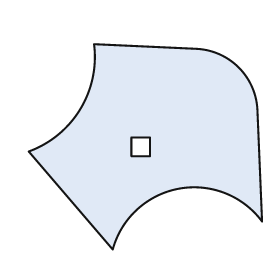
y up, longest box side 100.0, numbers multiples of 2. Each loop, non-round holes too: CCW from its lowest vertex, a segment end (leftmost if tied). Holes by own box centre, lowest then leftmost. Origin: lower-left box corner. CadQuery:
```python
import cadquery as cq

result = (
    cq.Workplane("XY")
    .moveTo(36.0, 0.0)
    .threePointArc((64.0, 26.0), (100.0, 12.0))
    .lineTo(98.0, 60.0)
    .threePointArc((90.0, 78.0), (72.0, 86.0))
    .lineTo(28.0, 88.0)
    .threePointArc((22.0, 60.0), (0.0, 42.0))
    .close()
    .moveTo(44.0, 40.0)
    .lineTo(52.0, 40.0)
    .lineTo(52.0, 48.0)
    .lineTo(44.0, 48.0)
    .close()
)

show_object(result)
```